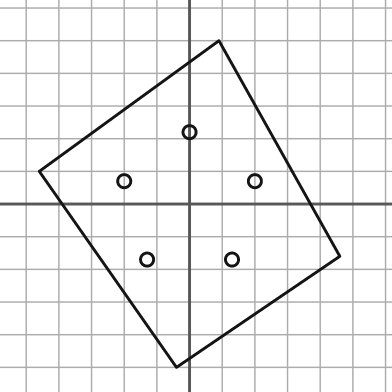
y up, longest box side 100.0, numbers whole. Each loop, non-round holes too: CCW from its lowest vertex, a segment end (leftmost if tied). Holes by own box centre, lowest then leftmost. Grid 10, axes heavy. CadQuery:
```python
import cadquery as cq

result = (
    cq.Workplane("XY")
    .moveTo(-4.0, -50.0)
    .lineTo(46.0, -16.0)
    .lineTo(9.0, 50.0)
    .lineTo(-46.0, 10.0)
    .close()
    .moveTo(-13.0, -17.0)
    .circle(2.0)
    .moveTo(13.0, -17.0)
    .circle(2.0)
    .moveTo(-20.0, 7.0)
    .circle(2.0)
    .moveTo(20.0, 7.0)
    .circle(2.0)
    .moveTo(0.0, 22.0)
    .circle(2.0)
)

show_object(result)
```